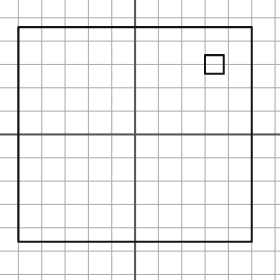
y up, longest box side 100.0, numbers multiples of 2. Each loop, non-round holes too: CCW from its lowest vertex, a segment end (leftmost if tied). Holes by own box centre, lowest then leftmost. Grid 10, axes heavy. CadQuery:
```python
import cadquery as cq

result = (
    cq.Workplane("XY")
    .moveTo(-50.0, -46.0)
    .lineTo(50.0, -46.0)
    .lineTo(50.0, 46.0)
    .lineTo(-50.0, 46.0)
    .close()
    .moveTo(30.0, 26.0)
    .lineTo(38.0, 26.0)
    .lineTo(38.0, 34.0)
    .lineTo(30.0, 34.0)
    .close()
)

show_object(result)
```